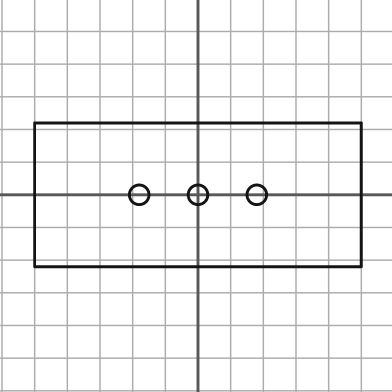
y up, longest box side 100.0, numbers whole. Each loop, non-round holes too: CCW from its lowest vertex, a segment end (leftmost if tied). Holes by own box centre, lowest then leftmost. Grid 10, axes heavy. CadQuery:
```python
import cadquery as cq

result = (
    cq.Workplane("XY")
    .moveTo(-50.0, -22.0)
    .lineTo(50.0, -22.0)
    .lineTo(50.0, 22.0)
    .lineTo(-50.0, 22.0)
    .close()
    .moveTo(-18.0, 0.0)
    .circle(3.0)
    .moveTo(0.0, 0.0)
    .circle(3.0)
    .moveTo(18.0, 0.0)
    .circle(3.0)
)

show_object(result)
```